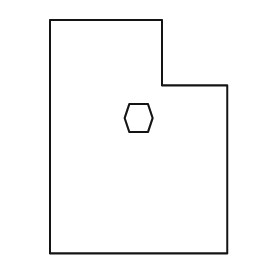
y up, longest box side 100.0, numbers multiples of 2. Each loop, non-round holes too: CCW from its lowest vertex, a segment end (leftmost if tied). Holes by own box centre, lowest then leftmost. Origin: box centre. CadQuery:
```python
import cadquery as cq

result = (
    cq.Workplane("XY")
    .moveTo(-38.0, -50.0)
    .lineTo(38.0, -50.0)
    .lineTo(38.0, 22.0)
    .lineTo(10.0, 22.0)
    .lineTo(10.0, 50.0)
    .lineTo(-38.0, 50.0)
    .close()
    .moveTo(-4.0, 2.0)
    .lineTo(4.0, 2.0)
    .lineTo(6.0, 8.0)
    .lineTo(4.0, 14.0)
    .lineTo(-4.0, 14.0)
    .lineTo(-6.0, 8.0)
    .close()
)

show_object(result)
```